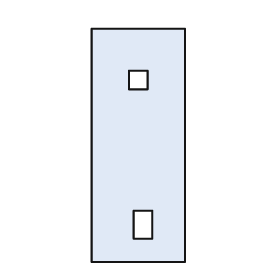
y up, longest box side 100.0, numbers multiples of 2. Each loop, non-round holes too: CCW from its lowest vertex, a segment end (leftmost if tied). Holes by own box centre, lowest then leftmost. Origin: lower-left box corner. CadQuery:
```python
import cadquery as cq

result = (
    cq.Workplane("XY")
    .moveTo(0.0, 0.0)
    .lineTo(40.0, 0.0)
    .lineTo(40.0, 100.0)
    .lineTo(0.0, 100.0)
    .close()
    .moveTo(18.0, 10.0)
    .lineTo(26.0, 10.0)
    .lineTo(26.0, 22.0)
    .lineTo(18.0, 22.0)
    .close()
    .moveTo(16.0, 74.0)
    .lineTo(24.0, 74.0)
    .lineTo(24.0, 82.0)
    .lineTo(16.0, 82.0)
    .close()
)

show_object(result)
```